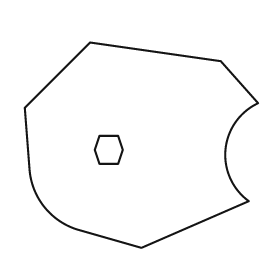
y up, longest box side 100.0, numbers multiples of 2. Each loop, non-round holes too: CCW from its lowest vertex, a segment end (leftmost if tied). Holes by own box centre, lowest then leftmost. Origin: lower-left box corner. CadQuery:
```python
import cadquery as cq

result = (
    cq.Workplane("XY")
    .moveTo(50.0, 0.0)
    .lineTo(96.0, 20.0)
    .threePointArc((86.0, 42.0), (100.0, 62.0))
    .lineTo(84.0, 80.0)
    .lineTo(28.0, 88.0)
    .lineTo(0.0, 60.0)
    .lineTo(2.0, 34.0)
    .threePointArc((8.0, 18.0), (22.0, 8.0))
    .close()
    .moveTo(32.0, 36.0)
    .lineTo(40.0, 36.0)
    .lineTo(42.0, 42.0)
    .lineTo(40.0, 48.0)
    .lineTo(32.0, 48.0)
    .lineTo(30.0, 42.0)
    .close()
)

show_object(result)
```